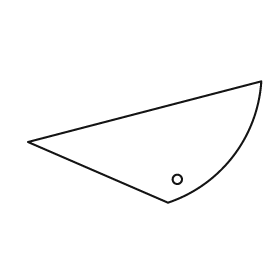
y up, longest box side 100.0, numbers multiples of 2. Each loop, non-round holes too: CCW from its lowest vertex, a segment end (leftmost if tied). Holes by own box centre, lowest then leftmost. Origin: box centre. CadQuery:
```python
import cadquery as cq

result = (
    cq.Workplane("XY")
    .moveTo(10.0, -26.0)
    .threePointArc((38.0, -6.0), (50.0, 26.0))
    .lineTo(-50.0, 0.0)
    .close()
    .moveTo(14.0, -16.0)
    .circle(2.0)
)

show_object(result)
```